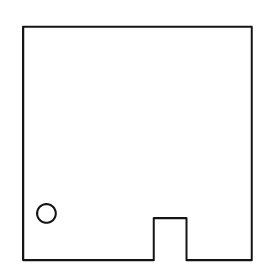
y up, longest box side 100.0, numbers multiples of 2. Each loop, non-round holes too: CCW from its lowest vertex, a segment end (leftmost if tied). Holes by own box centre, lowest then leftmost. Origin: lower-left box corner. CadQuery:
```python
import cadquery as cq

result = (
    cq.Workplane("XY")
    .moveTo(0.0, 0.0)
    .lineTo(56.0, 0.0)
    .lineTo(56.0, 18.0)
    .lineTo(70.0, 18.0)
    .lineTo(70.0, 0.0)
    .lineTo(98.0, 0.0)
    .lineTo(98.0, 100.0)
    .lineTo(0.0, 100.0)
    .close()
    .moveTo(10.0, 20.0)
    .circle(4.0)
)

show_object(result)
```